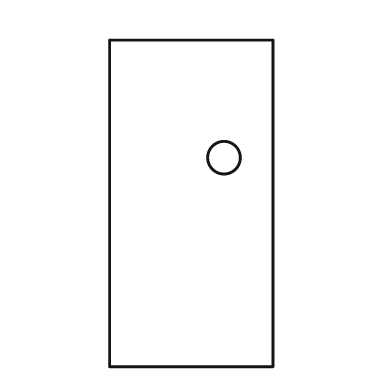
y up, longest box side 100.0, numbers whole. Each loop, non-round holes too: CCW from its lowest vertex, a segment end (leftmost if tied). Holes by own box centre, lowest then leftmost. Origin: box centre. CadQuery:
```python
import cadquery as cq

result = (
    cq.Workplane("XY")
    .moveTo(-25.0, -50.0)
    .lineTo(25.0, -50.0)
    .lineTo(25.0, 50.0)
    .lineTo(-25.0, 50.0)
    .close()
    .moveTo(10.0, 14.0)
    .circle(5.0)
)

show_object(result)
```